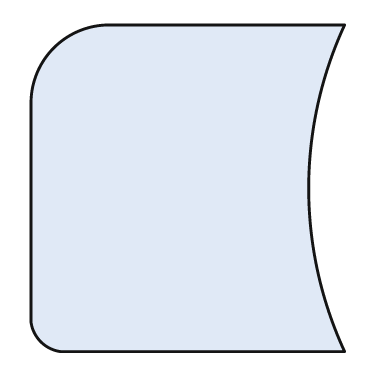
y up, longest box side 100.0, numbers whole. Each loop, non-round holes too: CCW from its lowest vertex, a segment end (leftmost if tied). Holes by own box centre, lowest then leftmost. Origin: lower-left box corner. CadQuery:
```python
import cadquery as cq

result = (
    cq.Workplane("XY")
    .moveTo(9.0, 0.0)
    .lineTo(96.0, 0.0)
    .threePointArc((85.0, 50.0), (96.0, 100.0))
    .lineTo(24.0, 100.0)
    .threePointArc((7.0, 93.0), (0.0, 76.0))
    .lineTo(0.0, 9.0)
    .threePointArc((3.0, 3.0), (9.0, 0.0))
    .close()
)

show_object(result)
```